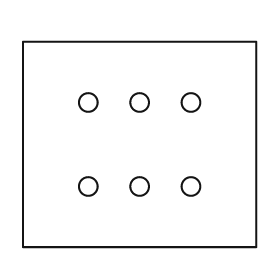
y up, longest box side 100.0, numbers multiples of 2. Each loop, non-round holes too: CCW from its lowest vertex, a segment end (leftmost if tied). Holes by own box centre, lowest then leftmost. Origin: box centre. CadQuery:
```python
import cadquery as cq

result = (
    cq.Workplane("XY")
    .moveTo(-50.0, -44.0)
    .lineTo(50.0, -44.0)
    .lineTo(50.0, 44.0)
    .lineTo(-50.0, 44.0)
    .close()
    .moveTo(-22.0, -18.0)
    .circle(4.0)
    .moveTo(0.0, -18.0)
    .circle(4.0)
    .moveTo(22.0, -18.0)
    .circle(4.0)
    .moveTo(-22.0, 18.0)
    .circle(4.0)
    .moveTo(0.0, 18.0)
    .circle(4.0)
    .moveTo(22.0, 18.0)
    .circle(4.0)
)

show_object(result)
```